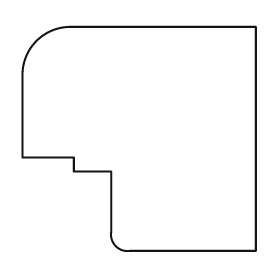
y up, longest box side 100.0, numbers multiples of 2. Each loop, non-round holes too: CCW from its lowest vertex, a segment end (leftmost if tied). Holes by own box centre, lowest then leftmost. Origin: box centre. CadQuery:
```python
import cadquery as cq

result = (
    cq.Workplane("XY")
    .moveTo(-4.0, -48.0)
    .lineTo(50.0, -48.0)
    .lineTo(50.0, 48.0)
    .lineTo(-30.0, 48.0)
    .threePointArc((-44.0, 42.0), (-50.0, 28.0))
    .lineTo(-50.0, -8.0)
    .lineTo(-28.0, -8.0)
    .lineTo(-28.0, -14.0)
    .lineTo(-12.0, -14.0)
    .lineTo(-12.0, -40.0)
    .threePointArc((-10.0, -46.0), (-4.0, -48.0))
    .close()
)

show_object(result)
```